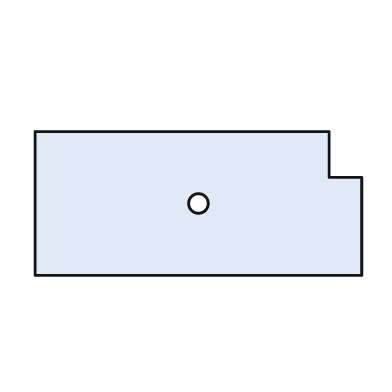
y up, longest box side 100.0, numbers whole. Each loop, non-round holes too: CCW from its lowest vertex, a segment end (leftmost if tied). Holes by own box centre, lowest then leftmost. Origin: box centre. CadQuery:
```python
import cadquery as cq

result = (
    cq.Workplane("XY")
    .moveTo(-50.0, -22.0)
    .lineTo(50.0, -22.0)
    .lineTo(50.0, 8.0)
    .lineTo(40.0, 8.0)
    .lineTo(40.0, 22.0)
    .lineTo(-50.0, 22.0)
    .close()
    .moveTo(0.0, 0.0)
    .circle(3.0)
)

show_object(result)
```